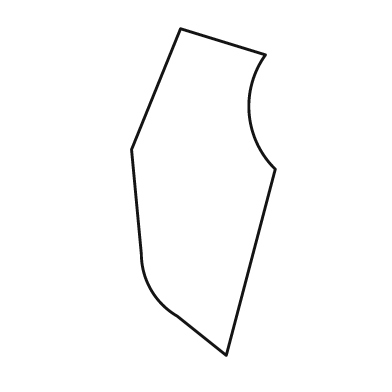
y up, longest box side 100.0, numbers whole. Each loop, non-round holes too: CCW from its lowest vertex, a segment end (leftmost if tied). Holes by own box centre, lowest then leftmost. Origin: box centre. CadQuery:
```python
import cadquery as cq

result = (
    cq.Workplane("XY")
    .moveTo(7.0, -50.0)
    .lineTo(22.0, 7.0)
    .threePointArc((14.0, 24.0), (19.0, 42.0))
    .lineTo(-7.0, 50.0)
    .lineTo(-22.0, 13.0)
    .lineTo(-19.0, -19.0)
    .threePointArc((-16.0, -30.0), (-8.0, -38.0))
    .close()
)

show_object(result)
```